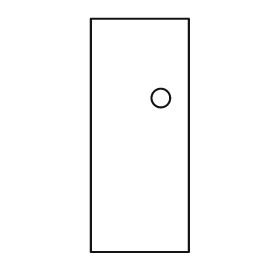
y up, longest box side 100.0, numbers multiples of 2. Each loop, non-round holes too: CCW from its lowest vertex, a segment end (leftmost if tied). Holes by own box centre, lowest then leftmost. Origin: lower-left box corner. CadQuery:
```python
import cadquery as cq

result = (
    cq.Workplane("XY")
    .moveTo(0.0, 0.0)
    .lineTo(42.0, 0.0)
    .lineTo(42.0, 100.0)
    .lineTo(0.0, 100.0)
    .close()
    .moveTo(30.0, 66.0)
    .circle(4.0)
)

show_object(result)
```